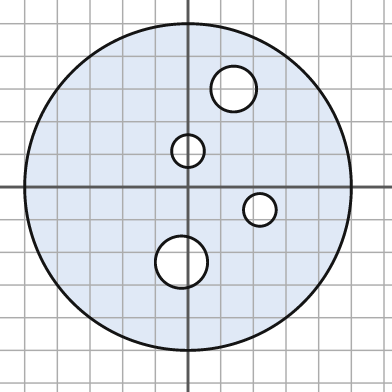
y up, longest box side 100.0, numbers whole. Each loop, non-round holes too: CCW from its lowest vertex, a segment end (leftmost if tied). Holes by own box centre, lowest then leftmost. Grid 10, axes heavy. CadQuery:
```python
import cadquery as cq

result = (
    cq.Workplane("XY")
    .moveTo(0.0, 0.0)
    .circle(50.0)
    .moveTo(-2.0, -23.0)
    .circle(8.0)
    .moveTo(22.0, -7.0)
    .circle(5.0)
    .moveTo(0.0, 11.0)
    .circle(5.0)
    .moveTo(14.0, 30.0)
    .circle(7.0)
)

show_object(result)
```